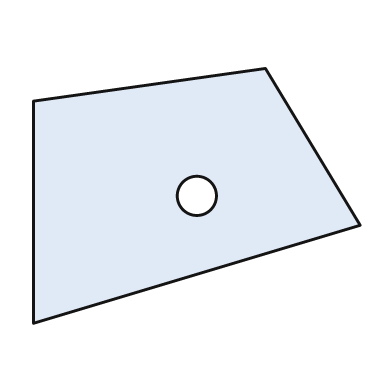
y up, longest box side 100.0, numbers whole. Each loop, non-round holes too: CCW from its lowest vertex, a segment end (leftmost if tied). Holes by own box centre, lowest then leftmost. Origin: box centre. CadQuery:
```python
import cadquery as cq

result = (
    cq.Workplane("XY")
    .moveTo(-50.0, -39.0)
    .lineTo(50.0, -9.0)
    .lineTo(21.0, 39.0)
    .lineTo(-50.0, 29.0)
    .close()
    .moveTo(0.0, 0.0)
    .circle(6.0)
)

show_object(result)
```